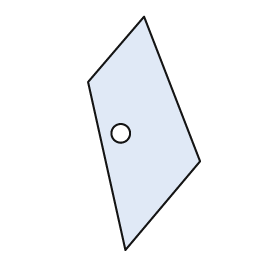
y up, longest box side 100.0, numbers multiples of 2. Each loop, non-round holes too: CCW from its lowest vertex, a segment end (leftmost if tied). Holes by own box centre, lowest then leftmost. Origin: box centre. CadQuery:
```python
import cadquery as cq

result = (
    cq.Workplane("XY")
    .moveTo(-8.0, -50.0)
    .lineTo(24.0, -12.0)
    .lineTo(0.0, 50.0)
    .lineTo(-24.0, 22.0)
    .close()
    .moveTo(-10.0, 0.0)
    .circle(4.0)
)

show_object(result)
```